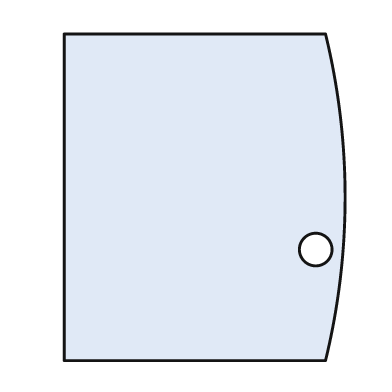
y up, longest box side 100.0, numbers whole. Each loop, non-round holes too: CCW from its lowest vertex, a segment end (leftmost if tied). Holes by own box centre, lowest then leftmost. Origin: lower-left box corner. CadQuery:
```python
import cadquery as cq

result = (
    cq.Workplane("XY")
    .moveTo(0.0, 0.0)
    .lineTo(80.0, 0.0)
    .threePointArc((86.0, 50.0), (80.0, 100.0))
    .lineTo(0.0, 100.0)
    .close()
    .moveTo(77.0, 34.0)
    .circle(5.0)
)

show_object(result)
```